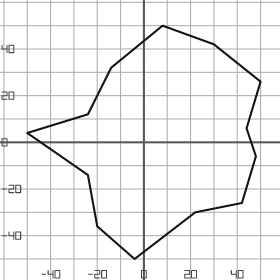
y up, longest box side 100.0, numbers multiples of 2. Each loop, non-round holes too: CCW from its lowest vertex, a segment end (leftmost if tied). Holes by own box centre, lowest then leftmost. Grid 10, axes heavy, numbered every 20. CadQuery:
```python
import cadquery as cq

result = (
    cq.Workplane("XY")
    .moveTo(-4.0, -50.0)
    .lineTo(22.0, -30.0)
    .lineTo(42.0, -26.0)
    .lineTo(48.0, -6.0)
    .lineTo(44.0, 6.0)
    .lineTo(50.0, 26.0)
    .lineTo(30.0, 42.0)
    .lineTo(8.0, 50.0)
    .lineTo(-14.0, 32.0)
    .lineTo(-24.0, 12.0)
    .lineTo(-50.0, 4.0)
    .lineTo(-24.0, -14.0)
    .lineTo(-20.0, -36.0)
    .close()
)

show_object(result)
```